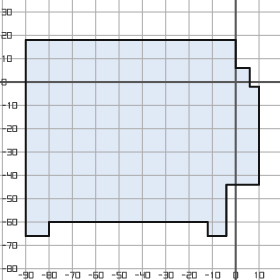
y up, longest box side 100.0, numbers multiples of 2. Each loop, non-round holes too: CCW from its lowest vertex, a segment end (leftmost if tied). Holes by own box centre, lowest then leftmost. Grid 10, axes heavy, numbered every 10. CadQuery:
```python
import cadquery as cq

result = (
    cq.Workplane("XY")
    .moveTo(-90.0, -66.0)
    .lineTo(-80.0, -66.0)
    .lineTo(-80.0, -60.0)
    .lineTo(-12.0, -60.0)
    .lineTo(-12.0, -66.0)
    .lineTo(-4.0, -66.0)
    .lineTo(-4.0, -44.0)
    .lineTo(10.0, -44.0)
    .lineTo(10.0, -2.0)
    .lineTo(6.0, -2.0)
    .lineTo(6.0, 6.0)
    .lineTo(0.0, 6.0)
    .lineTo(0.0, 18.0)
    .lineTo(-90.0, 18.0)
    .close()
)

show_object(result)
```